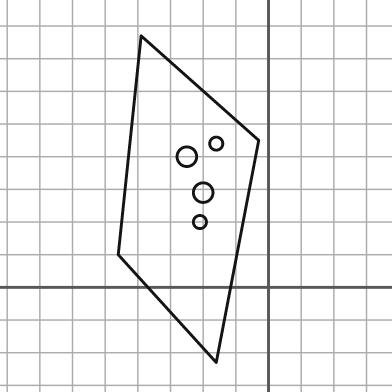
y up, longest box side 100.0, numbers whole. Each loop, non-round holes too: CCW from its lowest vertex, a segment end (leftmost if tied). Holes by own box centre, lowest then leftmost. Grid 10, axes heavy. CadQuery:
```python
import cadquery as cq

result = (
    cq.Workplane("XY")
    .moveTo(-16.0, -23.0)
    .lineTo(-3.0, 45.0)
    .lineTo(-39.0, 77.0)
    .lineTo(-46.0, 10.0)
    .close()
    .moveTo(-21.0, 20.0)
    .circle(2.0)
    .moveTo(-20.0, 29.0)
    .circle(3.0)
    .moveTo(-25.0, 40.0)
    .circle(3.0)
    .moveTo(-16.0, 44.0)
    .circle(2.0)
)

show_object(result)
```